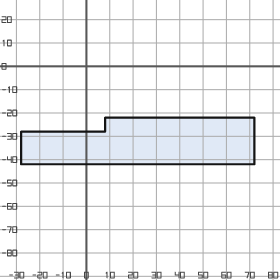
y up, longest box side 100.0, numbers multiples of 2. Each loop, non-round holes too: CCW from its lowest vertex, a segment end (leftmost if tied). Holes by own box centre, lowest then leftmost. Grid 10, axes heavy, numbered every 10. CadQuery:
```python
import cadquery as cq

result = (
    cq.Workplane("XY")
    .moveTo(-28.0, -42.0)
    .lineTo(72.0, -42.0)
    .lineTo(72.0, -22.0)
    .lineTo(8.0, -22.0)
    .lineTo(8.0, -28.0)
    .lineTo(-28.0, -28.0)
    .close()
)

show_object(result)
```